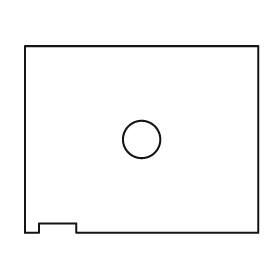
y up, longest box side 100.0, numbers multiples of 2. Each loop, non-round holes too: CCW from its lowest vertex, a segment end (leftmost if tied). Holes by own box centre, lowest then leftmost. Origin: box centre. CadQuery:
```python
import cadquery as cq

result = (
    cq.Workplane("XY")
    .moveTo(-50.0, -40.0)
    .lineTo(-44.0, -40.0)
    .lineTo(-44.0, -36.0)
    .lineTo(-28.0, -36.0)
    .lineTo(-28.0, -40.0)
    .lineTo(50.0, -40.0)
    .lineTo(50.0, 40.0)
    .lineTo(-50.0, 40.0)
    .close()
    .moveTo(0.0, 0.0)
    .circle(8.0)
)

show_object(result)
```